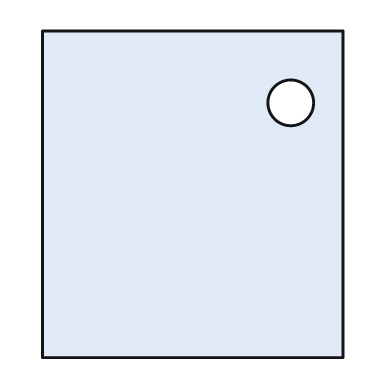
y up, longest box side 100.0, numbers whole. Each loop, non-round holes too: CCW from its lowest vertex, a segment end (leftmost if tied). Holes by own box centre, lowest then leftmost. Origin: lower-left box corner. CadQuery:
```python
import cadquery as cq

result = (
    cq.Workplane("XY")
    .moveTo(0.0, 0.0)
    .lineTo(92.0, 0.0)
    .lineTo(92.0, 100.0)
    .lineTo(0.0, 100.0)
    .close()
    .moveTo(76.0, 78.0)
    .circle(7.0)
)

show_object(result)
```